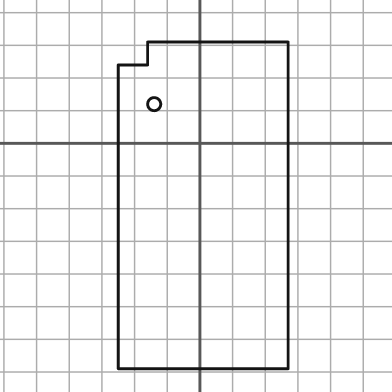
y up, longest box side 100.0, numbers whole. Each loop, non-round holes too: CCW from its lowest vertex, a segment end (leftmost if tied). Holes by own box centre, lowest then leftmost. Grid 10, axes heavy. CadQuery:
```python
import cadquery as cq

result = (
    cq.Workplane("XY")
    .moveTo(-25.0, -69.0)
    .lineTo(27.0, -69.0)
    .lineTo(27.0, 31.0)
    .lineTo(-16.0, 31.0)
    .lineTo(-16.0, 24.0)
    .lineTo(-25.0, 24.0)
    .close()
    .moveTo(-14.0, 12.0)
    .circle(2.0)
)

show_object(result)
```